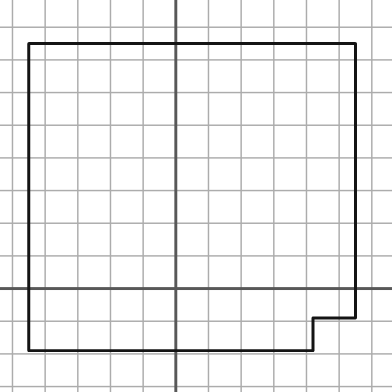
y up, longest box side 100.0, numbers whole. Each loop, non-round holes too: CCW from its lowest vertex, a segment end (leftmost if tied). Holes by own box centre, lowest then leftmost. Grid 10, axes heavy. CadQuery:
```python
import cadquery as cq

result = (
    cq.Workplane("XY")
    .moveTo(-45.0, -19.0)
    .lineTo(42.0, -19.0)
    .lineTo(42.0, -9.0)
    .lineTo(55.0, -9.0)
    .lineTo(55.0, 75.0)
    .lineTo(-45.0, 75.0)
    .close()
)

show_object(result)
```